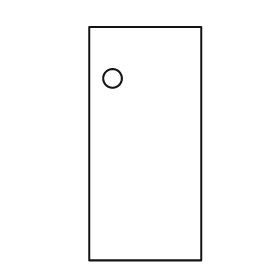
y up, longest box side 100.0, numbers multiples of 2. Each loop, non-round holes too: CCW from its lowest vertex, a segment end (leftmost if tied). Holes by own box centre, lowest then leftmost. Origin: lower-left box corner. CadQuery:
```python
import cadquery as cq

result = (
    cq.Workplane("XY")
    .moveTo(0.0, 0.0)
    .lineTo(48.0, 0.0)
    .lineTo(48.0, 100.0)
    .lineTo(0.0, 100.0)
    .close()
    .moveTo(10.0, 78.0)
    .circle(4.0)
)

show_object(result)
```